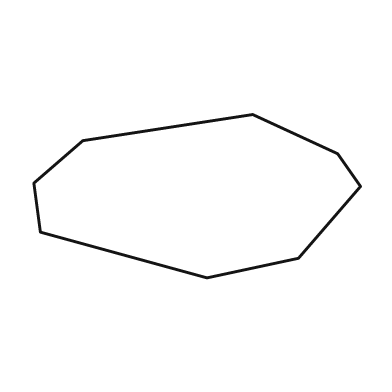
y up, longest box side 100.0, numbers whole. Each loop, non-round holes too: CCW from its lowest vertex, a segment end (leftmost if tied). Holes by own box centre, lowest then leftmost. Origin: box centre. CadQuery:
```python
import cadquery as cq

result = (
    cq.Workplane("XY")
    .moveTo(3.0, -25.0)
    .lineTo(31.0, -19.0)
    .lineTo(50.0, 3.0)
    .lineTo(43.0, 13.0)
    .lineTo(17.0, 25.0)
    .lineTo(-35.0, 17.0)
    .lineTo(-50.0, 4.0)
    .lineTo(-48.0, -11.0)
    .close()
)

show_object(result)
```